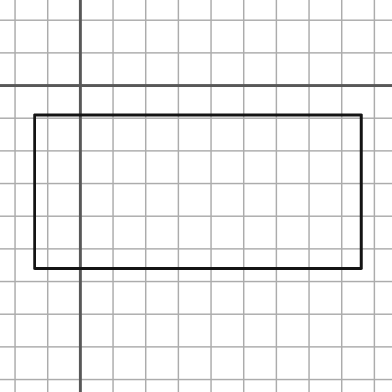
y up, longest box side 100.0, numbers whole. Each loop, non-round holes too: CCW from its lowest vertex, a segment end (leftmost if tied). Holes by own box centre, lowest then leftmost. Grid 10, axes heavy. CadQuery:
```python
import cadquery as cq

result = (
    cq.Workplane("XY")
    .moveTo(-14.0, -56.0)
    .lineTo(86.0, -56.0)
    .lineTo(86.0, -9.0)
    .lineTo(-14.0, -9.0)
    .close()
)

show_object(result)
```